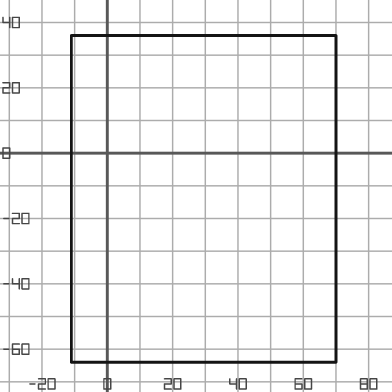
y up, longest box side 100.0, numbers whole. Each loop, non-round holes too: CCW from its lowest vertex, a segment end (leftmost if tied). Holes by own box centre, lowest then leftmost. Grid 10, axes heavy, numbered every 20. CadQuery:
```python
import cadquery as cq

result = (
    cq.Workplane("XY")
    .moveTo(-11.0, -64.0)
    .lineTo(70.0, -64.0)
    .lineTo(70.0, 36.0)
    .lineTo(-11.0, 36.0)
    .close()
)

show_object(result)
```